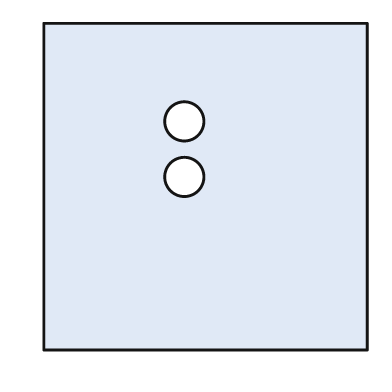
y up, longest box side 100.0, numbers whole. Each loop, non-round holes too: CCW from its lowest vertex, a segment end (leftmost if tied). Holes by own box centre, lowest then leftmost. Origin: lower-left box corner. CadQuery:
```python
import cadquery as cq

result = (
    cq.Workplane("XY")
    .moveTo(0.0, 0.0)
    .lineTo(99.0, 0.0)
    .lineTo(99.0, 100.0)
    .lineTo(0.0, 100.0)
    .close()
    .moveTo(43.0, 53.0)
    .circle(6.0)
    .moveTo(43.0, 70.0)
    .circle(6.0)
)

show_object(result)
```